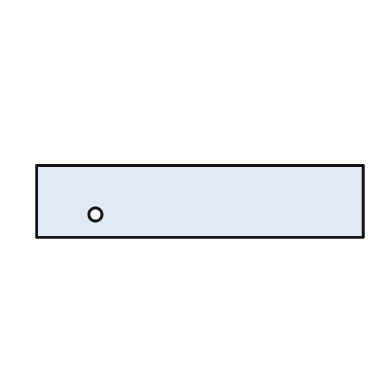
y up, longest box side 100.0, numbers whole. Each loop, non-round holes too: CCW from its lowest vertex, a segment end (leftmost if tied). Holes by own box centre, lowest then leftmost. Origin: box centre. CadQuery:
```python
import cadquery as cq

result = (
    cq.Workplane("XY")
    .moveTo(-50.0, -11.0)
    .lineTo(50.0, -11.0)
    .lineTo(50.0, 11.0)
    .lineTo(-50.0, 11.0)
    .close()
    .moveTo(-32.0, -4.0)
    .circle(2.0)
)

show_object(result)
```